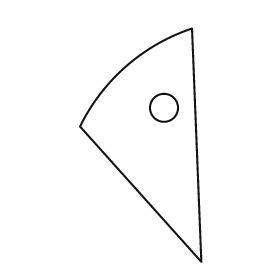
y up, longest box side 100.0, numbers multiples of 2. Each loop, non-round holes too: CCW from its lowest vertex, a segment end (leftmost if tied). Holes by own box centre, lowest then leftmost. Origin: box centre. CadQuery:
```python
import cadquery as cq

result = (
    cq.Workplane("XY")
    .moveTo(26.0, -50.0)
    .lineTo(22.0, 50.0)
    .threePointArc((-6.0, 34.0), (-26.0, 8.0))
    .close()
    .moveTo(10.0, 16.0)
    .circle(6.0)
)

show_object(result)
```